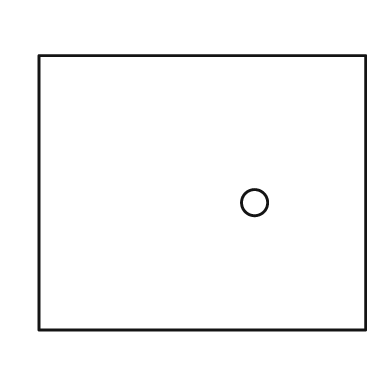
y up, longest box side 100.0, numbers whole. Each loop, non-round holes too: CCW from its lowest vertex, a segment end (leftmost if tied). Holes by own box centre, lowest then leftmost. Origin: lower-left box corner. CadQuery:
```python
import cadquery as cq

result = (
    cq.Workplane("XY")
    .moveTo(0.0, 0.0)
    .lineTo(100.0, 0.0)
    .lineTo(100.0, 84.0)
    .lineTo(0.0, 84.0)
    .close()
    .moveTo(66.0, 39.0)
    .circle(4.0)
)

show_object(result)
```